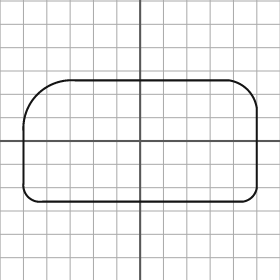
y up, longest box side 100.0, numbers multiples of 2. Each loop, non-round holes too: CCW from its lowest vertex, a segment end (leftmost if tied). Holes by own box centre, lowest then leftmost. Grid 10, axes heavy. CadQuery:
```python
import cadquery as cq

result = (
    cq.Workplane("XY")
    .moveTo(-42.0, -26.0)
    .lineTo(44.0, -26.0)
    .threePointArc((48.0, -24.0), (50.0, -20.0))
    .lineTo(50.0, 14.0)
    .threePointArc((46.0, 22.0), (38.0, 26.0))
    .lineTo(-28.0, 26.0)
    .threePointArc((-44.0, 20.0), (-50.0, 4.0))
    .lineTo(-50.0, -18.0)
    .threePointArc((-48.0, -24.0), (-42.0, -26.0))
    .close()
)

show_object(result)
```